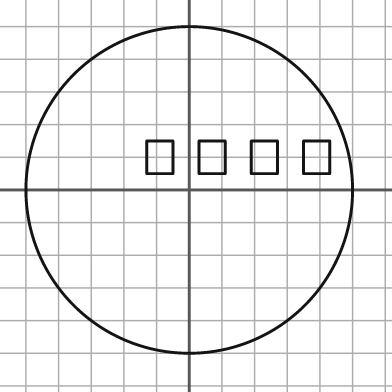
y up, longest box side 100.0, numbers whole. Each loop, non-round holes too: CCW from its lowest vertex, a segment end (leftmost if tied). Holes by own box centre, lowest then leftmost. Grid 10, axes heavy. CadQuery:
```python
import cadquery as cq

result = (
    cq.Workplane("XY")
    .moveTo(0.0, 0.0)
    .circle(50.0)
    .moveTo(-13.0, 5.0)
    .lineTo(-5.0, 5.0)
    .lineTo(-5.0, 15.0)
    .lineTo(-13.0, 15.0)
    .close()
    .moveTo(3.0, 5.0)
    .lineTo(11.0, 5.0)
    .lineTo(11.0, 15.0)
    .lineTo(3.0, 15.0)
    .close()
    .moveTo(19.0, 5.0)
    .lineTo(27.0, 5.0)
    .lineTo(27.0, 15.0)
    .lineTo(19.0, 15.0)
    .close()
    .moveTo(35.0, 5.0)
    .lineTo(43.0, 5.0)
    .lineTo(43.0, 15.0)
    .lineTo(35.0, 15.0)
    .close()
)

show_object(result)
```